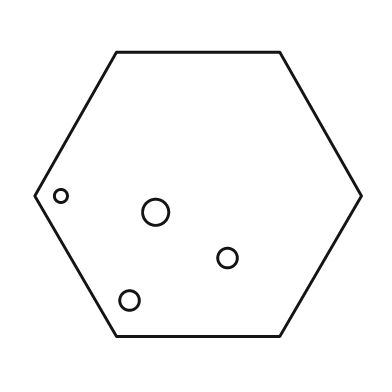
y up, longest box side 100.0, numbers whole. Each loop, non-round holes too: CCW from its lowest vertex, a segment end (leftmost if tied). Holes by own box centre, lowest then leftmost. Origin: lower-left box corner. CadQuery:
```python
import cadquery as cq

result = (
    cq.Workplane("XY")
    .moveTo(25.0, 0.0)
    .lineTo(75.0, 0.0)
    .lineTo(100.0, 43.0)
    .lineTo(75.0, 87.0)
    .lineTo(25.0, 87.0)
    .lineTo(0.0, 43.0)
    .close()
    .moveTo(29.0, 11.0)
    .circle(3.0)
    .moveTo(59.0, 24.0)
    .circle(3.0)
    .moveTo(37.0, 38.0)
    .circle(4.0)
    .moveTo(8.0, 43.0)
    .circle(2.0)
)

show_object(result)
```